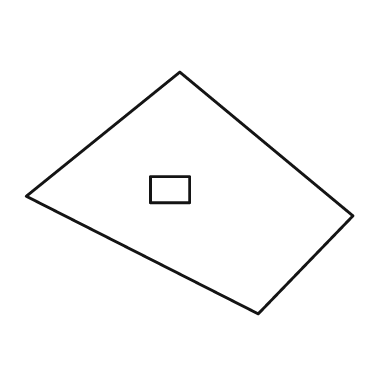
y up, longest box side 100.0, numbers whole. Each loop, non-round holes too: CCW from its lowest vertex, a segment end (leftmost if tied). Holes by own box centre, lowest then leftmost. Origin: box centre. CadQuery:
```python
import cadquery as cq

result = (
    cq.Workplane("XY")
    .moveTo(21.0, -37.0)
    .lineTo(50.0, -7.0)
    .lineTo(-3.0, 37.0)
    .lineTo(-50.0, -1.0)
    .close()
    .moveTo(-12.0, -3.0)
    .lineTo(0.0, -3.0)
    .lineTo(0.0, 5.0)
    .lineTo(-12.0, 5.0)
    .close()
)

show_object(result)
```